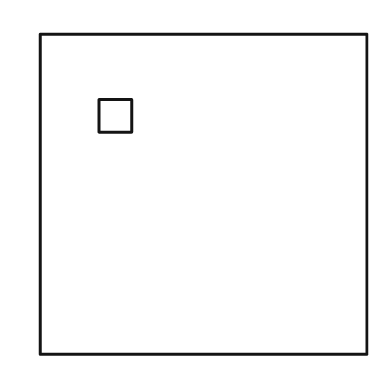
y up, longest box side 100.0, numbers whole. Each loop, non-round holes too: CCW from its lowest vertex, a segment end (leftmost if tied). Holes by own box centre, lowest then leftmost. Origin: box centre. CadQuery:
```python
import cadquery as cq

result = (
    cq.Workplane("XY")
    .moveTo(-50.0, -49.0)
    .lineTo(50.0, -49.0)
    .lineTo(50.0, 49.0)
    .lineTo(-50.0, 49.0)
    .close()
    .moveTo(-32.0, 19.0)
    .lineTo(-22.0, 19.0)
    .lineTo(-22.0, 29.0)
    .lineTo(-32.0, 29.0)
    .close()
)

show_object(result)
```